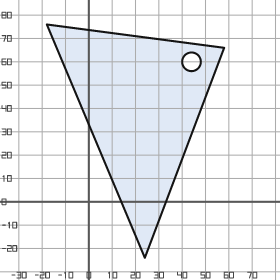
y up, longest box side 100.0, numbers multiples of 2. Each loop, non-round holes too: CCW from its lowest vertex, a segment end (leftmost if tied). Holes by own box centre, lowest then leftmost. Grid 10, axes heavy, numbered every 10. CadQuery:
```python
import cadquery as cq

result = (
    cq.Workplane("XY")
    .moveTo(24.0, -24.0)
    .lineTo(58.0, 66.0)
    .lineTo(-18.0, 76.0)
    .close()
    .moveTo(44.0, 60.0)
    .circle(4.0)
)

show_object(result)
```